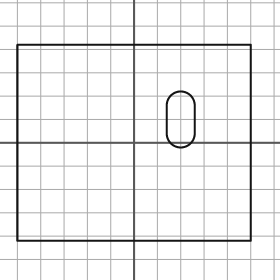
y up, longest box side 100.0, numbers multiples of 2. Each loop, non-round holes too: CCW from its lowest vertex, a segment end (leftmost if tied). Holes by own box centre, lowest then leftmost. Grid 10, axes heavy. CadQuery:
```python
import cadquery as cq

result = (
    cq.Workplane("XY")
    .moveTo(-50.0, -42.0)
    .lineTo(50.0, -42.0)
    .lineTo(50.0, 42.0)
    .lineTo(-50.0, 42.0)
    .close()
    .moveTo(14.0, 4.0)
    .threePointArc((20.0, -2.0), (26.0, 4.0))
    .lineTo(26.0, 16.0)
    .threePointArc((20.0, 22.0), (14.0, 16.0))
    .close()
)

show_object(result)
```